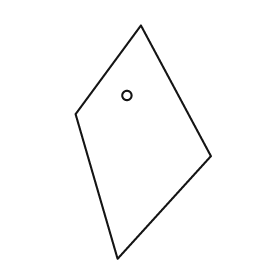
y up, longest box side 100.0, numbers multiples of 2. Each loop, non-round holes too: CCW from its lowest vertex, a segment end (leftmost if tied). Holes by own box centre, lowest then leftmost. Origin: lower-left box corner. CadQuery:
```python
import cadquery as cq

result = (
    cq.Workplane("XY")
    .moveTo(18.0, 0.0)
    .lineTo(58.0, 44.0)
    .lineTo(28.0, 100.0)
    .lineTo(0.0, 62.0)
    .close()
    .moveTo(22.0, 70.0)
    .circle(2.0)
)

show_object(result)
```